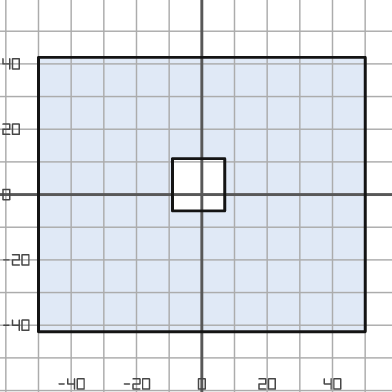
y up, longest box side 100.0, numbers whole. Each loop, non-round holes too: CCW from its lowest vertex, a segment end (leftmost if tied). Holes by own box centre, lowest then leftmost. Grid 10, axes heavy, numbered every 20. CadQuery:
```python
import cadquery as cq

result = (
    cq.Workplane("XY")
    .moveTo(-50.0, -42.0)
    .lineTo(50.0, -42.0)
    .lineTo(50.0, 42.0)
    .lineTo(-50.0, 42.0)
    .close()
    .moveTo(-9.0, -5.0)
    .lineTo(7.0, -5.0)
    .lineTo(7.0, 11.0)
    .lineTo(-9.0, 11.0)
    .close()
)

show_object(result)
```